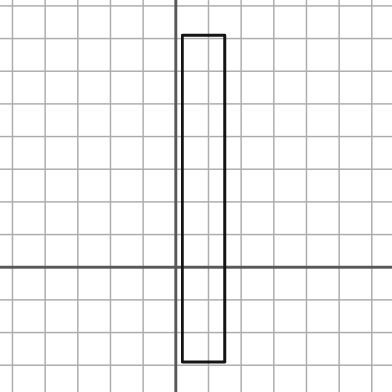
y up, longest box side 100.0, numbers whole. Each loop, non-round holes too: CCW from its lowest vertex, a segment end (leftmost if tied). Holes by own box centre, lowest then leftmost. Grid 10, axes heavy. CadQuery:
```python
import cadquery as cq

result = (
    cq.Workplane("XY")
    .moveTo(2.0, -29.0)
    .lineTo(15.0, -29.0)
    .lineTo(15.0, 71.0)
    .lineTo(2.0, 71.0)
    .close()
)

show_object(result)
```